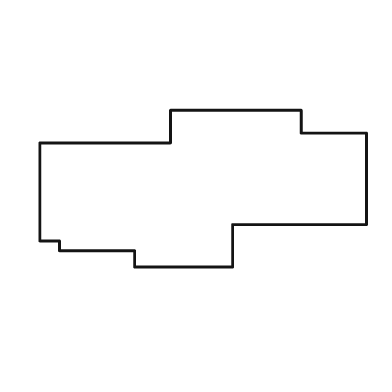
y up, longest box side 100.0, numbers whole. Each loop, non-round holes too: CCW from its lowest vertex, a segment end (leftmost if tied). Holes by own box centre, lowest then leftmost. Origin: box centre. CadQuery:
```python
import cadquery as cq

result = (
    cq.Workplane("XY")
    .moveTo(-21.0, -24.0)
    .lineTo(9.0, -24.0)
    .lineTo(9.0, -11.0)
    .lineTo(50.0, -11.0)
    .lineTo(50.0, 17.0)
    .lineTo(30.0, 17.0)
    .lineTo(30.0, 24.0)
    .lineTo(-10.0, 24.0)
    .lineTo(-10.0, 14.0)
    .lineTo(-50.0, 14.0)
    .lineTo(-50.0, -16.0)
    .lineTo(-44.0, -16.0)
    .lineTo(-44.0, -19.0)
    .lineTo(-21.0, -19.0)
    .close()
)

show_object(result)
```